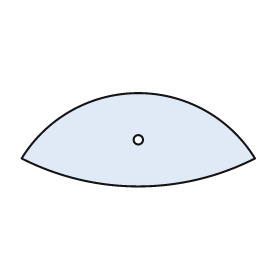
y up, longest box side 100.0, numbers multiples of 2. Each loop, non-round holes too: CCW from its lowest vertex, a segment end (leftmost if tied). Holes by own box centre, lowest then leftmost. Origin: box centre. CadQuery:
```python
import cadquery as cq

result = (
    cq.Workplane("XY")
    .moveTo(-50.0, -8.0)
    .threePointArc((0.0, -20.0), (50.0, -8.0))
    .threePointArc((0.0, 20.0), (-50.0, -8.0))
    .close()
    .moveTo(0.0, 0.0)
    .circle(2.0)
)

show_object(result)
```